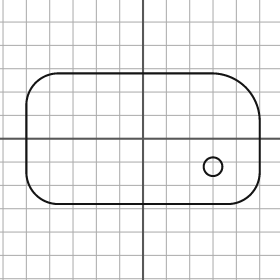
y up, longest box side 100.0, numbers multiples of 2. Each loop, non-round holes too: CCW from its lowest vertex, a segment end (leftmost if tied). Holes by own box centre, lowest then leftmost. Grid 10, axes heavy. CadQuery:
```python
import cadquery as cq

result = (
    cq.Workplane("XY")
    .moveTo(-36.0, -28.0)
    .lineTo(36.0, -28.0)
    .threePointArc((46.0, -24.0), (50.0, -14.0))
    .lineTo(50.0, 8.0)
    .threePointArc((44.0, 22.0), (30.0, 28.0))
    .lineTo(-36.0, 28.0)
    .threePointArc((-46.0, 24.0), (-50.0, 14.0))
    .lineTo(-50.0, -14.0)
    .threePointArc((-46.0, -24.0), (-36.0, -28.0))
    .close()
    .moveTo(30.0, -12.0)
    .circle(4.0)
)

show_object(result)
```